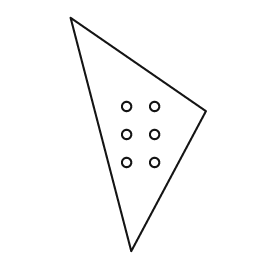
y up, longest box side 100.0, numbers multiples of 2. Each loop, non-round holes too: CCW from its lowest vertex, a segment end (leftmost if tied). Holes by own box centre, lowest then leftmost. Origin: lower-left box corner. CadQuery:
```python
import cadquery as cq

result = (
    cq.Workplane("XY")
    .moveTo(26.0, 0.0)
    .lineTo(58.0, 60.0)
    .lineTo(0.0, 100.0)
    .close()
    .moveTo(24.0, 38.0)
    .circle(2.0)
    .moveTo(36.0, 38.0)
    .circle(2.0)
    .moveTo(24.0, 50.0)
    .circle(2.0)
    .moveTo(36.0, 50.0)
    .circle(2.0)
    .moveTo(24.0, 62.0)
    .circle(2.0)
    .moveTo(36.0, 62.0)
    .circle(2.0)
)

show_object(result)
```